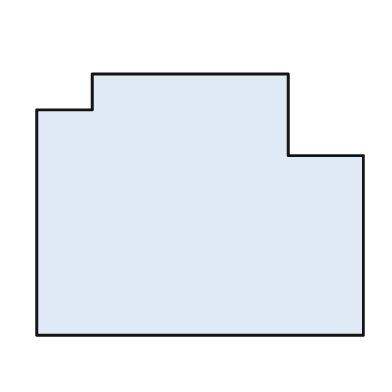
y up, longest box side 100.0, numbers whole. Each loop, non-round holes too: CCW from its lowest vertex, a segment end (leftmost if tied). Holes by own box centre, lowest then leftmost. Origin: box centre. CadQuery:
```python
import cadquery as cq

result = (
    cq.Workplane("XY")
    .moveTo(-50.0, -40.0)
    .lineTo(50.0, -40.0)
    .lineTo(50.0, 15.0)
    .lineTo(27.0, 15.0)
    .lineTo(27.0, 40.0)
    .lineTo(-33.0, 40.0)
    .lineTo(-33.0, 29.0)
    .lineTo(-50.0, 29.0)
    .close()
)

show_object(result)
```